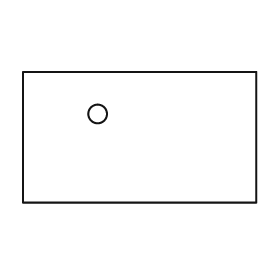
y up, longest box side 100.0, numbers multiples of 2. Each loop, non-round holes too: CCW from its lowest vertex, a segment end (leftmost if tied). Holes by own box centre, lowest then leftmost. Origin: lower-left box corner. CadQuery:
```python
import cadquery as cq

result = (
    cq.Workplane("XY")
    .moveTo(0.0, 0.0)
    .lineTo(100.0, 0.0)
    .lineTo(100.0, 56.0)
    .lineTo(0.0, 56.0)
    .close()
    .moveTo(32.0, 38.0)
    .circle(4.0)
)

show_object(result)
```